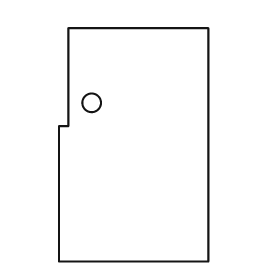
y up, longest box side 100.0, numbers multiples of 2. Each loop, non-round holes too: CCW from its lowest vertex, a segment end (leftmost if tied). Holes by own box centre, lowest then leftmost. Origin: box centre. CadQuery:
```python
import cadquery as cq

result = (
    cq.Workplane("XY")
    .moveTo(-32.0, -50.0)
    .lineTo(32.0, -50.0)
    .lineTo(32.0, 50.0)
    .lineTo(-28.0, 50.0)
    .lineTo(-28.0, 8.0)
    .lineTo(-32.0, 8.0)
    .close()
    .moveTo(-18.0, 18.0)
    .circle(4.0)
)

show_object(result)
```